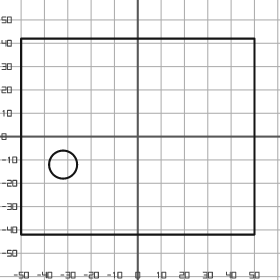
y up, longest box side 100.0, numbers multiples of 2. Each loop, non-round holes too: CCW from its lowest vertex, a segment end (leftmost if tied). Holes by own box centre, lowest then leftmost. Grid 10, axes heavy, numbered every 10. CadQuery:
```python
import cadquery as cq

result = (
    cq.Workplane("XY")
    .moveTo(-50.0, -42.0)
    .lineTo(50.0, -42.0)
    .lineTo(50.0, 42.0)
    .lineTo(-50.0, 42.0)
    .close()
    .moveTo(-32.0, -12.0)
    .circle(6.0)
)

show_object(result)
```